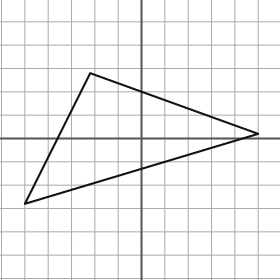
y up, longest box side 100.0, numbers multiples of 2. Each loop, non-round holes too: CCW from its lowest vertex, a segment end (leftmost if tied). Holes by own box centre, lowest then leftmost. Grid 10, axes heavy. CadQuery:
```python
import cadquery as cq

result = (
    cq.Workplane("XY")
    .moveTo(-50.0, -28.0)
    .lineTo(50.0, 2.0)
    .lineTo(-22.0, 28.0)
    .close()
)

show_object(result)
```